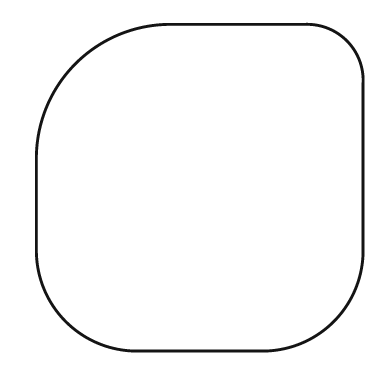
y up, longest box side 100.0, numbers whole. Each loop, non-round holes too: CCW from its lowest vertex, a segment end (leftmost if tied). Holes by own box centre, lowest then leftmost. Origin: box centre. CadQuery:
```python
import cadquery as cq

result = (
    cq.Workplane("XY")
    .moveTo(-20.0, -50.0)
    .lineTo(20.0, -50.0)
    .threePointArc((41.0, -41.0), (50.0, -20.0))
    .lineTo(50.0, 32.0)
    .threePointArc((45.0, 45.0), (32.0, 50.0))
    .lineTo(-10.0, 50.0)
    .threePointArc((-38.0, 38.0), (-50.0, 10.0))
    .lineTo(-50.0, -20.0)
    .threePointArc((-41.0, -41.0), (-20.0, -50.0))
    .close()
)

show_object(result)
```